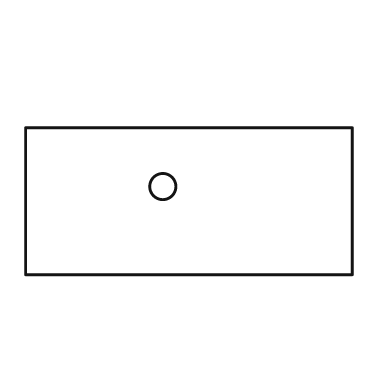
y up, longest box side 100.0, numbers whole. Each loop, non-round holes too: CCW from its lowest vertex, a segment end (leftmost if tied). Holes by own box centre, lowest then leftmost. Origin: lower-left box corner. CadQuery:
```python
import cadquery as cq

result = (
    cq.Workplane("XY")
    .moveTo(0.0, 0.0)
    .lineTo(100.0, 0.0)
    .lineTo(100.0, 45.0)
    .lineTo(0.0, 45.0)
    .close()
    .moveTo(42.0, 27.0)
    .circle(4.0)
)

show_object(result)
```